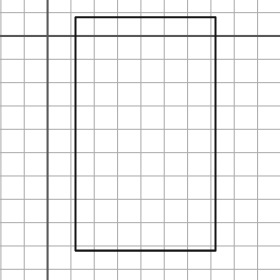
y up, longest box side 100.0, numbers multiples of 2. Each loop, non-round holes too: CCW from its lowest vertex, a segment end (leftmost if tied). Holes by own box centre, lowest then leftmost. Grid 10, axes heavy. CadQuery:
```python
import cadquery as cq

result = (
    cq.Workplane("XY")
    .moveTo(12.0, -92.0)
    .lineTo(72.0, -92.0)
    .lineTo(72.0, 8.0)
    .lineTo(12.0, 8.0)
    .close()
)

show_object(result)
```